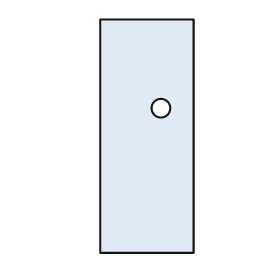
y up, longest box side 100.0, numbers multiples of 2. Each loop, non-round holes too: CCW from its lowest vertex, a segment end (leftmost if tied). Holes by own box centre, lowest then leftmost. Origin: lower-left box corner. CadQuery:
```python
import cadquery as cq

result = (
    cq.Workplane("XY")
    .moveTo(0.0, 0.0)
    .lineTo(40.0, 0.0)
    .lineTo(40.0, 100.0)
    .lineTo(0.0, 100.0)
    .close()
    .moveTo(26.0, 62.0)
    .circle(4.0)
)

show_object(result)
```